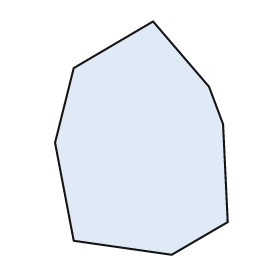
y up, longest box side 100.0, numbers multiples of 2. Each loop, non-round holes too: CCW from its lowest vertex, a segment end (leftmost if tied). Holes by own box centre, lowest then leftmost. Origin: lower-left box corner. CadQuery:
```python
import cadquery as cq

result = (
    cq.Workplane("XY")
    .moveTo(50.0, 0.0)
    .lineTo(74.0, 14.0)
    .lineTo(72.0, 56.0)
    .lineTo(66.0, 72.0)
    .lineTo(42.0, 100.0)
    .lineTo(8.0, 80.0)
    .lineTo(0.0, 48.0)
    .lineTo(8.0, 6.0)
    .close()
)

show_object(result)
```